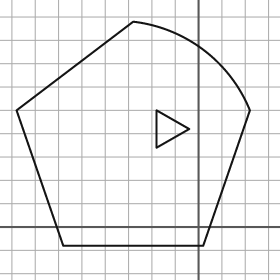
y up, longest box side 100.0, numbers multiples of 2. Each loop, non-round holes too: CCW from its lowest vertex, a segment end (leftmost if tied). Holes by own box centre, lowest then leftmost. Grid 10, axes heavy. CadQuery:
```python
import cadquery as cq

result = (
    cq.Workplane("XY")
    .moveTo(-58.0, -8.0)
    .lineTo(2.0, -8.0)
    .lineTo(22.0, 50.0)
    .threePointArc((2.0, 76.0), (-28.0, 88.0))
    .lineTo(-78.0, 50.0)
    .close()
    .moveTo(-18.0, 34.0)
    .lineTo(-4.0, 42.0)
    .lineTo(-18.0, 50.0)
    .close()
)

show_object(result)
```